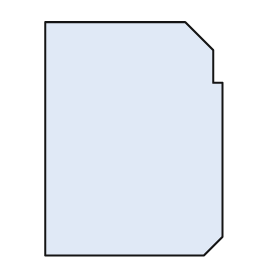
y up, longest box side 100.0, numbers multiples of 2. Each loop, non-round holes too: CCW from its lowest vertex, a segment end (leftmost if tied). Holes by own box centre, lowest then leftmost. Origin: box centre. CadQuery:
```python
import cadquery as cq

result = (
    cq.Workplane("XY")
    .moveTo(-38.0, -50.0)
    .lineTo(30.0, -50.0)
    .lineTo(38.0, -42.0)
    .lineTo(38.0, 24.0)
    .lineTo(34.0, 24.0)
    .lineTo(34.0, 38.0)
    .lineTo(22.0, 50.0)
    .lineTo(-38.0, 50.0)
    .close()
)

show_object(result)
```